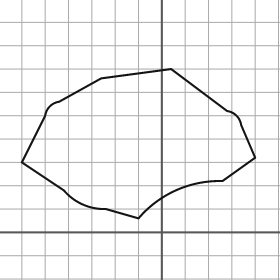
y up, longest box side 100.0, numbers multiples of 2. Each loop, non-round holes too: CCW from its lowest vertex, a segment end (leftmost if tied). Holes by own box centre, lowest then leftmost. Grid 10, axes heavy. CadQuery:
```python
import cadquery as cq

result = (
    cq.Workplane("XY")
    .moveTo(-10.0, 6.0)
    .threePointArc((6.0, 18.0), (26.0, 22.0))
    .lineTo(40.0, 32.0)
    .lineTo(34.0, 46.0)
    .threePointArc((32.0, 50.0), (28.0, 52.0))
    .lineTo(4.0, 70.0)
    .lineTo(-26.0, 66.0)
    .lineTo(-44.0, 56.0)
    .threePointArc((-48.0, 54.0), (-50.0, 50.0))
    .lineTo(-60.0, 30.0)
    .lineTo(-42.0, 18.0)
    .threePointArc((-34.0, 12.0), (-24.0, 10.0))
    .close()
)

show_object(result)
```